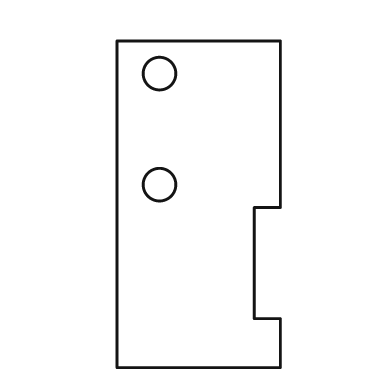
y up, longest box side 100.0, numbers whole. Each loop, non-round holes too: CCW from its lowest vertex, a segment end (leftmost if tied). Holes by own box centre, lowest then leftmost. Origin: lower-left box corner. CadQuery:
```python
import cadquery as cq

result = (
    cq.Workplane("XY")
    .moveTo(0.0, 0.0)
    .lineTo(50.0, 0.0)
    .lineTo(50.0, 15.0)
    .lineTo(42.0, 15.0)
    .lineTo(42.0, 49.0)
    .lineTo(50.0, 49.0)
    .lineTo(50.0, 100.0)
    .lineTo(0.0, 100.0)
    .close()
    .moveTo(13.0, 56.0)
    .circle(5.0)
    .moveTo(13.0, 90.0)
    .circle(5.0)
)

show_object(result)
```